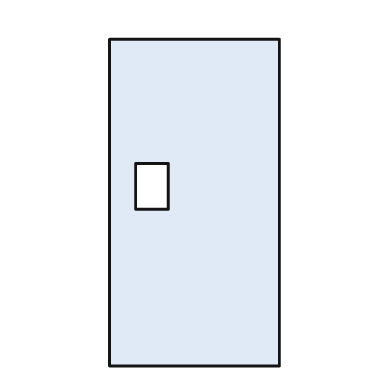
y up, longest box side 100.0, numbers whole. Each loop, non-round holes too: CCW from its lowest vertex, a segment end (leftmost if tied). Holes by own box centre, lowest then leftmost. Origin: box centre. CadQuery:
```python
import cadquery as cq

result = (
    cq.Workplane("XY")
    .moveTo(-26.0, -50.0)
    .lineTo(26.0, -50.0)
    .lineTo(26.0, 50.0)
    .lineTo(-26.0, 50.0)
    .close()
    .moveTo(-18.0, -2.0)
    .lineTo(-8.0, -2.0)
    .lineTo(-8.0, 12.0)
    .lineTo(-18.0, 12.0)
    .close()
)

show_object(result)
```